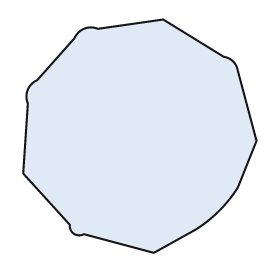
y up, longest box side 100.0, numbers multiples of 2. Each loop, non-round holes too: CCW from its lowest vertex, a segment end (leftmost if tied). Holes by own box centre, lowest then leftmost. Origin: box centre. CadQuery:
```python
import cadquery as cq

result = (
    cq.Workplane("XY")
    .moveTo(6.0, -50.0)
    .lineTo(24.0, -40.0)
    .threePointArc((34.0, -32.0), (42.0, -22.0))
    .lineTo(50.0, -2.0)
    .lineTo(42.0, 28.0)
    .threePointArc((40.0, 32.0), (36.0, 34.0))
    .lineTo(10.0, 50.0)
    .lineTo(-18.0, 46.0)
    .threePointArc((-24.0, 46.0), (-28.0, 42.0))
    .lineTo(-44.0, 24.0)
    .threePointArc((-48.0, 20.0), (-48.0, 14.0))
    .lineTo(-50.0, -16.0)
    .lineTo(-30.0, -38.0)
    .threePointArc((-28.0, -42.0), (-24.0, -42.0))
    .close()
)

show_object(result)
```